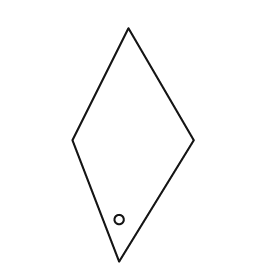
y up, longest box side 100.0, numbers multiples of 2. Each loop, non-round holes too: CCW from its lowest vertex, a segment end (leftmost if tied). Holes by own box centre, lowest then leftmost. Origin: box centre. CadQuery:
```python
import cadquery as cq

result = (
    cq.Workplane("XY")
    .moveTo(-6.0, -50.0)
    .lineTo(26.0, 2.0)
    .lineTo(-2.0, 50.0)
    .lineTo(-26.0, 2.0)
    .close()
    .moveTo(-6.0, -32.0)
    .circle(2.0)
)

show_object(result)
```